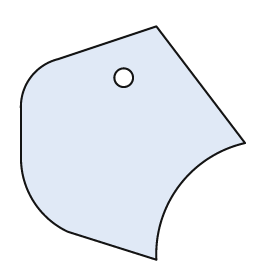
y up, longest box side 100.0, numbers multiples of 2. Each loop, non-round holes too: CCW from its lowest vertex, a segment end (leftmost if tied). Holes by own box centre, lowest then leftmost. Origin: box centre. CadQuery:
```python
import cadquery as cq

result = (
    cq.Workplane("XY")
    .moveTo(10.0, -50.0)
    .threePointArc((20.0, -18.0), (48.0, 0.0))
    .lineTo(10.0, 50.0)
    .lineTo(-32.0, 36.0)
    .threePointArc((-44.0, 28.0), (-48.0, 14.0))
    .lineTo(-48.0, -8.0)
    .threePointArc((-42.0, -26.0), (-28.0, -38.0))
    .close()
    .moveTo(-4.0, 28.0)
    .circle(4.0)
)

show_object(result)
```